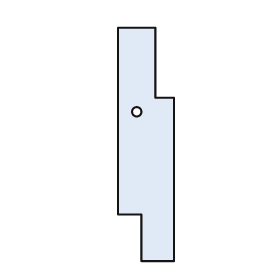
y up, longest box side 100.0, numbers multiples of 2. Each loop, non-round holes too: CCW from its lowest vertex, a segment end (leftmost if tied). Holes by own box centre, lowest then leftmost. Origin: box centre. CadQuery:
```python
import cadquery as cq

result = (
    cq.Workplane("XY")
    .moveTo(-2.0, -50.0)
    .lineTo(12.0, -50.0)
    .lineTo(12.0, 20.0)
    .lineTo(4.0, 20.0)
    .lineTo(4.0, 50.0)
    .lineTo(-12.0, 50.0)
    .lineTo(-12.0, -30.0)
    .lineTo(-2.0, -30.0)
    .close()
    .moveTo(-4.0, 14.0)
    .circle(2.0)
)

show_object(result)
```